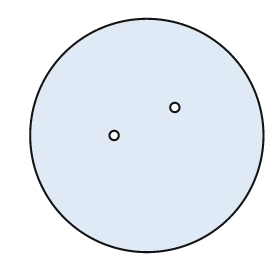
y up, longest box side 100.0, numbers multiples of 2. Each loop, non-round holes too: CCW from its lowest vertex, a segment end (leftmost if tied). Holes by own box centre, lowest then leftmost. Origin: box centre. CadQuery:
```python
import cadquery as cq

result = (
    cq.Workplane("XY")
    .moveTo(0.0, 0.0)
    .circle(50.0)
    .moveTo(-14.0, 0.0)
    .circle(2.0)
    .moveTo(12.0, 12.0)
    .circle(2.0)
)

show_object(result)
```